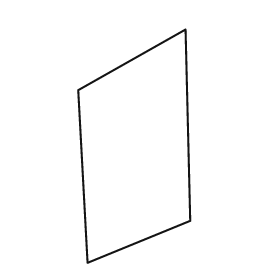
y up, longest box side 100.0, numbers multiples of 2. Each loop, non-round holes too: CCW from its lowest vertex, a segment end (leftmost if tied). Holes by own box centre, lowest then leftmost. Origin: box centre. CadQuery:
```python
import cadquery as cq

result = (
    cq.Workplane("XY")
    .moveTo(-20.0, -50.0)
    .lineTo(24.0, -32.0)
    .lineTo(22.0, 50.0)
    .lineTo(-24.0, 24.0)
    .close()
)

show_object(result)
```